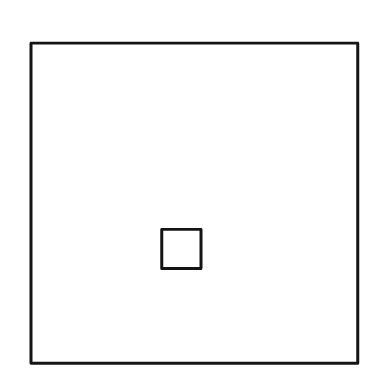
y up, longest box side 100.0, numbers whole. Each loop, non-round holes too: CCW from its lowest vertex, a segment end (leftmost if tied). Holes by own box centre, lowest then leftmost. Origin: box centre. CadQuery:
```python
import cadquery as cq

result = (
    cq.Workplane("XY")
    .moveTo(-50.0, -49.0)
    .lineTo(50.0, -49.0)
    .lineTo(50.0, 49.0)
    .lineTo(-50.0, 49.0)
    .close()
    .moveTo(-10.0, -20.0)
    .lineTo(2.0, -20.0)
    .lineTo(2.0, -8.0)
    .lineTo(-10.0, -8.0)
    .close()
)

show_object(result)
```